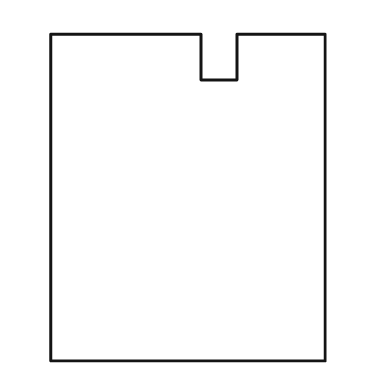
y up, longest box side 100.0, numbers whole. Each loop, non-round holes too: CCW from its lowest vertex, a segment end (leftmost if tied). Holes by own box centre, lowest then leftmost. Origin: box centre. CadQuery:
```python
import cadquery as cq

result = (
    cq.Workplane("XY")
    .moveTo(-42.0, -50.0)
    .lineTo(42.0, -50.0)
    .lineTo(42.0, 50.0)
    .lineTo(15.0, 50.0)
    .lineTo(15.0, 36.0)
    .lineTo(4.0, 36.0)
    .lineTo(4.0, 50.0)
    .lineTo(-42.0, 50.0)
    .close()
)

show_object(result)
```